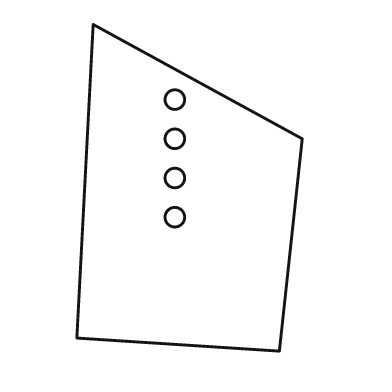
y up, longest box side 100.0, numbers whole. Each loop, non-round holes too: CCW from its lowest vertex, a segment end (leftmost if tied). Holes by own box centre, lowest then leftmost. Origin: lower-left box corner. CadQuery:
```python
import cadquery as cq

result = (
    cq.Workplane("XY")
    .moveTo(62.0, 0.0)
    .lineTo(69.0, 65.0)
    .lineTo(5.0, 100.0)
    .lineTo(0.0, 4.0)
    .close()
    .moveTo(30.0, 41.0)
    .circle(3.0)
    .moveTo(30.0, 53.0)
    .circle(3.0)
    .moveTo(30.0, 65.0)
    .circle(3.0)
    .moveTo(30.0, 77.0)
    .circle(3.0)
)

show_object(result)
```